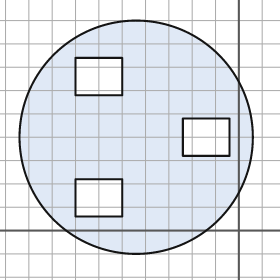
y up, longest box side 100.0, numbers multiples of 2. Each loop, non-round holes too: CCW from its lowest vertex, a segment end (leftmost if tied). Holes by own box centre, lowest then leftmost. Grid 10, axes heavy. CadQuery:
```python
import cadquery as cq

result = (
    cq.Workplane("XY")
    .moveTo(-44.0, 40.0)
    .circle(50.0)
    .moveTo(-70.0, 6.0)
    .lineTo(-50.0, 6.0)
    .lineTo(-50.0, 22.0)
    .lineTo(-70.0, 22.0)
    .close()
    .moveTo(-24.0, 32.0)
    .lineTo(-4.0, 32.0)
    .lineTo(-4.0, 48.0)
    .lineTo(-24.0, 48.0)
    .close()
    .moveTo(-70.0, 58.0)
    .lineTo(-50.0, 58.0)
    .lineTo(-50.0, 74.0)
    .lineTo(-70.0, 74.0)
    .close()
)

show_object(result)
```